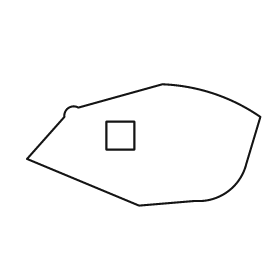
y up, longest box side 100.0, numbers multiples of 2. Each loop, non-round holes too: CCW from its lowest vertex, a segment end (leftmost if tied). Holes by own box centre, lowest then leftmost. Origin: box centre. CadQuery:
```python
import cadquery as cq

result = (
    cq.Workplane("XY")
    .moveTo(-2.0, -26.0)
    .lineTo(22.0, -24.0)
    .threePointArc((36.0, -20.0), (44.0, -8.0))
    .lineTo(50.0, 12.0)
    .threePointArc((30.0, 22.0), (8.0, 26.0))
    .lineTo(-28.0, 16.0)
    .threePointArc((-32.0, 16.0), (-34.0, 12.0))
    .lineTo(-50.0, -6.0)
    .close()
    .moveTo(-16.0, -2.0)
    .lineTo(-4.0, -2.0)
    .lineTo(-4.0, 10.0)
    .lineTo(-16.0, 10.0)
    .close()
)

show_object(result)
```